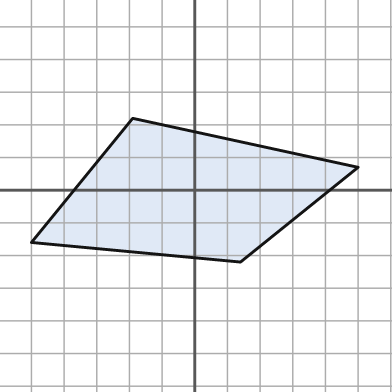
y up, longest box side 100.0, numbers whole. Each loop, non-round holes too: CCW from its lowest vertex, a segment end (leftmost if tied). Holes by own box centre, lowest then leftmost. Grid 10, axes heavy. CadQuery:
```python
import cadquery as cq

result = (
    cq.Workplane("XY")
    .moveTo(14.0, -22.0)
    .lineTo(50.0, 7.0)
    .lineTo(-19.0, 22.0)
    .lineTo(-50.0, -16.0)
    .close()
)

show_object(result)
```